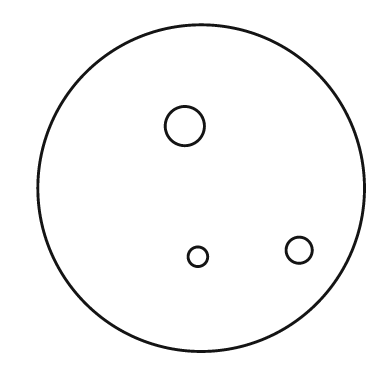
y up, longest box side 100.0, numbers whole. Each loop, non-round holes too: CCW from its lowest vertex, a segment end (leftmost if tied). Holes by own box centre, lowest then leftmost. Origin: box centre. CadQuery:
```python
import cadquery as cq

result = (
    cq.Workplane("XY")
    .moveTo(0.0, 0.0)
    .circle(50.0)
    .moveTo(-1.0, -21.0)
    .circle(3.0)
    .moveTo(30.0, -19.0)
    .circle(4.0)
    .moveTo(-5.0, 19.0)
    .circle(6.0)
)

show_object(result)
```